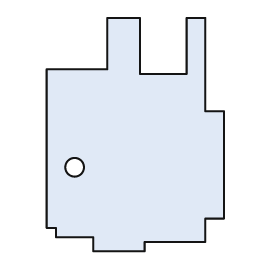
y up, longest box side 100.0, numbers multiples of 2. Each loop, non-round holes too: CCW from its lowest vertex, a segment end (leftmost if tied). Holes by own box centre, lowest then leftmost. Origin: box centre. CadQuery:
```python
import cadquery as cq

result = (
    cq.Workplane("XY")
    .moveTo(-18.0, -50.0)
    .lineTo(4.0, -50.0)
    .lineTo(4.0, -46.0)
    .lineTo(30.0, -46.0)
    .lineTo(30.0, -36.0)
    .lineTo(38.0, -36.0)
    .lineTo(38.0, 10.0)
    .lineTo(30.0, 10.0)
    .lineTo(30.0, 50.0)
    .lineTo(22.0, 50.0)
    .lineTo(22.0, 26.0)
    .lineTo(2.0, 26.0)
    .lineTo(2.0, 50.0)
    .lineTo(-12.0, 50.0)
    .lineTo(-12.0, 28.0)
    .lineTo(-38.0, 28.0)
    .lineTo(-38.0, -40.0)
    .lineTo(-34.0, -40.0)
    .lineTo(-34.0, -44.0)
    .lineTo(-18.0, -44.0)
    .close()
    .moveTo(-26.0, -14.0)
    .circle(4.0)
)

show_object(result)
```